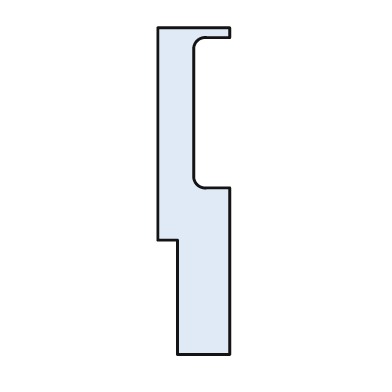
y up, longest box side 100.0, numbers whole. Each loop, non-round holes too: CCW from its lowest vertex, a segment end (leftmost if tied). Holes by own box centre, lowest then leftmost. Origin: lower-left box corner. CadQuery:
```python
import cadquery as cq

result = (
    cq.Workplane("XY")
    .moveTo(6.0, 0.0)
    .lineTo(22.0, 0.0)
    .lineTo(22.0, 51.0)
    .lineTo(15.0, 51.0)
    .threePointArc((12.0, 52.0), (11.0, 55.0))
    .lineTo(11.0, 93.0)
    .threePointArc((12.0, 96.0), (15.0, 97.0))
    .lineTo(22.0, 97.0)
    .lineTo(22.0, 100.0)
    .lineTo(0.0, 100.0)
    .lineTo(0.0, 35.0)
    .lineTo(6.0, 35.0)
    .close()
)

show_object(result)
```